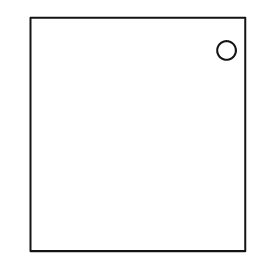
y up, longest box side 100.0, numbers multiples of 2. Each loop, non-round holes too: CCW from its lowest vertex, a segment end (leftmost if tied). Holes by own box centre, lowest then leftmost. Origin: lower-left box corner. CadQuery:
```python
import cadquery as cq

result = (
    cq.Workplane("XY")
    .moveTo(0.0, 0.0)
    .lineTo(92.0, 0.0)
    .lineTo(92.0, 100.0)
    .lineTo(0.0, 100.0)
    .close()
    .moveTo(84.0, 86.0)
    .circle(4.0)
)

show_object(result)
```